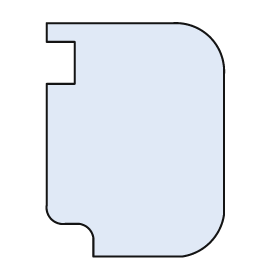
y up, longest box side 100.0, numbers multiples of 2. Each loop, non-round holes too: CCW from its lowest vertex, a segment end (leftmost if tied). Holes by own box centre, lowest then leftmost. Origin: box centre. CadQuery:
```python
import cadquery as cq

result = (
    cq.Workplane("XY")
    .moveTo(-18.0, -50.0)
    .lineTo(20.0, -50.0)
    .threePointArc((32.0, -44.0), (38.0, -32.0))
    .lineTo(38.0, 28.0)
    .threePointArc((32.0, 44.0), (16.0, 50.0))
    .lineTo(-38.0, 50.0)
    .lineTo(-38.0, 42.0)
    .lineTo(-26.0, 42.0)
    .lineTo(-26.0, 24.0)
    .lineTo(-38.0, 24.0)
    .lineTo(-38.0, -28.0)
    .threePointArc((-36.0, -34.0), (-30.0, -36.0))
    .lineTo(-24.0, -36.0)
    .threePointArc((-20.0, -38.0), (-18.0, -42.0))
    .close()
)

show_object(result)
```